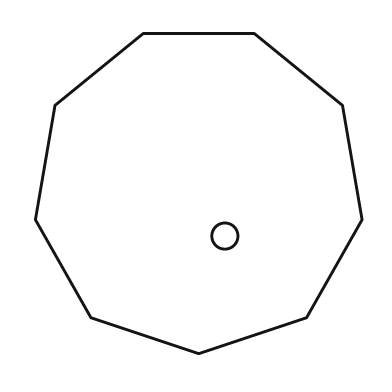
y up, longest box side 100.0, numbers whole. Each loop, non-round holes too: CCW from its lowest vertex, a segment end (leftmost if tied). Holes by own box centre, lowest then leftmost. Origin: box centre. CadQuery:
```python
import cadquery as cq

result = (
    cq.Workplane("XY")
    .moveTo(0.0, -49.0)
    .lineTo(33.0, -38.0)
    .lineTo(50.0, -8.0)
    .lineTo(44.0, 27.0)
    .lineTo(17.0, 49.0)
    .lineTo(-17.0, 49.0)
    .lineTo(-44.0, 27.0)
    .lineTo(-50.0, -8.0)
    .lineTo(-33.0, -38.0)
    .close()
    .moveTo(8.0, -13.0)
    .circle(4.0)
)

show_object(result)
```